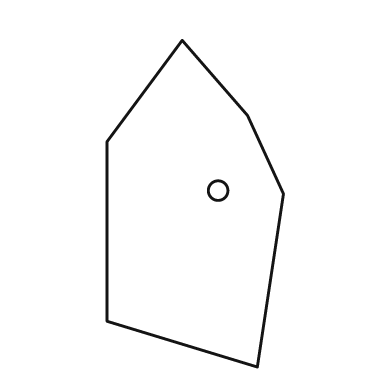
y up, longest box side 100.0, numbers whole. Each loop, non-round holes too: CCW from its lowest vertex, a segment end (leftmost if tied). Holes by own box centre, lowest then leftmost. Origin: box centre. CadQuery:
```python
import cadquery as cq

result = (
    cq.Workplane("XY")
    .moveTo(19.0, -50.0)
    .lineTo(27.0, 3.0)
    .lineTo(16.0, 27.0)
    .lineTo(-4.0, 50.0)
    .lineTo(-27.0, 19.0)
    .lineTo(-27.0, -36.0)
    .close()
    .moveTo(7.0, 4.0)
    .circle(3.0)
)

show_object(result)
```